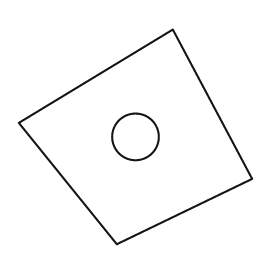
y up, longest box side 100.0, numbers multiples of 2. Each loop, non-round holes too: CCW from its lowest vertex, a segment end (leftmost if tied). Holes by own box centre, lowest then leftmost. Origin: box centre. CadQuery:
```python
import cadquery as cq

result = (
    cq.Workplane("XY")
    .moveTo(-8.0, -46.0)
    .lineTo(50.0, -18.0)
    .lineTo(16.0, 46.0)
    .lineTo(-50.0, 6.0)
    .close()
    .moveTo(0.0, 0.0)
    .circle(10.0)
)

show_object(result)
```